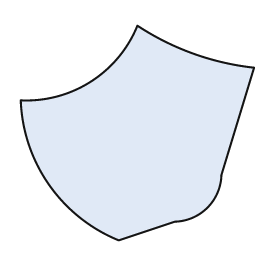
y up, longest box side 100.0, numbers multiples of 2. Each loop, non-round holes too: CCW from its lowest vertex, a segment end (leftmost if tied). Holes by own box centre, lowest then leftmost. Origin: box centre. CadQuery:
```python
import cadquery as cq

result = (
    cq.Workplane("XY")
    .moveTo(-8.0, -46.0)
    .lineTo(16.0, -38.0)
    .threePointArc((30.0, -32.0), (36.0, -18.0))
    .lineTo(50.0, 28.0)
    .threePointArc((24.0, 34.0), (0.0, 46.0))
    .threePointArc((-20.0, 22.0), (-50.0, 14.0))
    .threePointArc((-38.0, -22.0), (-8.0, -46.0))
    .close()
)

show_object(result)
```